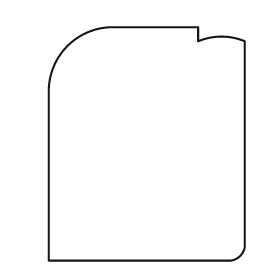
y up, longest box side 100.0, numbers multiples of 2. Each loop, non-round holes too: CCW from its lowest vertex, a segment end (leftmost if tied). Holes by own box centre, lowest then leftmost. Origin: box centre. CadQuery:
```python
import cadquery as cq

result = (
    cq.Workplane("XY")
    .moveTo(-42.0, -50.0)
    .lineTo(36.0, -50.0)
    .threePointArc((40.0, -48.0), (42.0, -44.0))
    .lineTo(42.0, 44.0)
    .threePointArc((32.0, 46.0), (22.0, 44.0))
    .lineTo(22.0, 50.0)
    .lineTo(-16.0, 50.0)
    .threePointArc((-34.0, 42.0), (-42.0, 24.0))
    .close()
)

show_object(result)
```